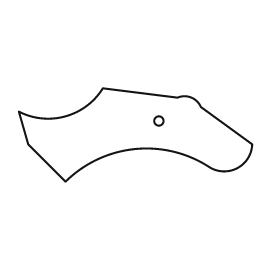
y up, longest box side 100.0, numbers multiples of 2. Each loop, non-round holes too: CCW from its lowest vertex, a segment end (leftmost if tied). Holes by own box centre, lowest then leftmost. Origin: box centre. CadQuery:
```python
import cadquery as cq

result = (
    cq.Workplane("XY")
    .moveTo(-30.0, -20.0)
    .threePointArc((0.0, -6.0), (32.0, -14.0))
    .threePointArc((44.0, -14.0), (50.0, -4.0))
    .lineTo(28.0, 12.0)
    .threePointArc((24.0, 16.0), (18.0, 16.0))
    .lineTo(-14.0, 20.0)
    .threePointArc((-30.0, 8.0), (-50.0, 10.0))
    .lineTo(-46.0, -4.0)
    .close()
    .moveTo(10.0, 6.0)
    .circle(2.0)
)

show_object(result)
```